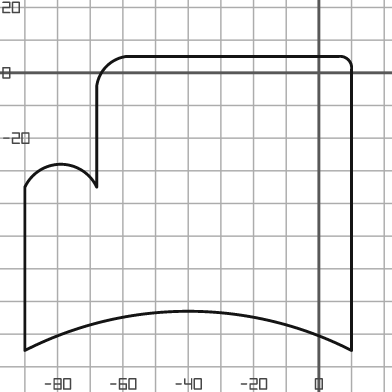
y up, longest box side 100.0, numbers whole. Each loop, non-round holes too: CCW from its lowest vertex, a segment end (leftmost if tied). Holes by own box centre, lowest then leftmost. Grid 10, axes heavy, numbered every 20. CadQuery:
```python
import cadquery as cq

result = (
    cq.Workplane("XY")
    .moveTo(-90.0, -85.0)
    .threePointArc((-40.0, -73.0), (10.0, -85.0))
    .lineTo(10.0, 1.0)
    .threePointArc((9.0, 4.0), (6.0, 5.0))
    .lineTo(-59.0, 5.0)
    .threePointArc((-65.0, 2.0), (-68.0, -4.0))
    .lineTo(-68.0, -35.0)
    .threePointArc((-79.0, -28.0), (-90.0, -35.0))
    .close()
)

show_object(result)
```